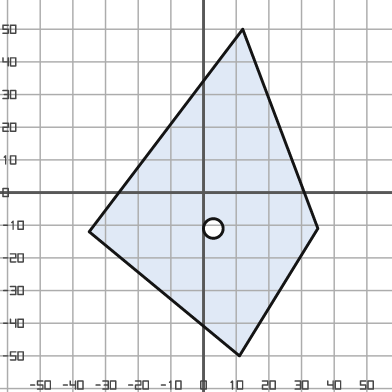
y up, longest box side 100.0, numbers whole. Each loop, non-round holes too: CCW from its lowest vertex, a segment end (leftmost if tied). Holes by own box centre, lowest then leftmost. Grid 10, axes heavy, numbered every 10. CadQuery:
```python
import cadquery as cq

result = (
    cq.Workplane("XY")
    .moveTo(11.0, -50.0)
    .lineTo(35.0, -11.0)
    .lineTo(12.0, 50.0)
    .lineTo(-35.0, -12.0)
    .close()
    .moveTo(3.0, -11.0)
    .circle(3.0)
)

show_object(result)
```